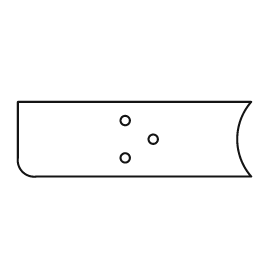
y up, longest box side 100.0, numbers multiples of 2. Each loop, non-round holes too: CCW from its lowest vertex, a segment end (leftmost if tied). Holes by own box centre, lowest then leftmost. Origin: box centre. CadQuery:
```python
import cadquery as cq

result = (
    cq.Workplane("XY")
    .moveTo(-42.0, -16.0)
    .lineTo(50.0, -16.0)
    .threePointArc((44.0, 0.0), (50.0, 16.0))
    .lineTo(-50.0, 16.0)
    .lineTo(-50.0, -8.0)
    .threePointArc((-48.0, -14.0), (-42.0, -16.0))
    .close()
    .moveTo(-4.0, -8.0)
    .circle(2.0)
    .moveTo(8.0, 0.0)
    .circle(2.0)
    .moveTo(-4.0, 8.0)
    .circle(2.0)
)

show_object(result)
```